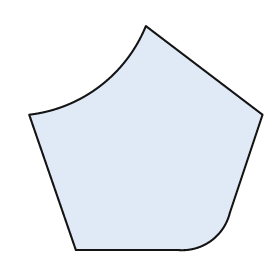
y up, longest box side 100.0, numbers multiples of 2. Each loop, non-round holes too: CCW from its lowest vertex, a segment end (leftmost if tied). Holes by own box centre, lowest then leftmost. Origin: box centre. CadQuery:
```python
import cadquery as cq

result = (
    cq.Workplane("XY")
    .moveTo(-30.0, -48.0)
    .lineTo(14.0, -48.0)
    .threePointArc((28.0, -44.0), (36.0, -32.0))
    .lineTo(50.0, 10.0)
    .lineTo(0.0, 48.0)
    .threePointArc((-20.0, 22.0), (-50.0, 10.0))
    .close()
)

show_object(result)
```